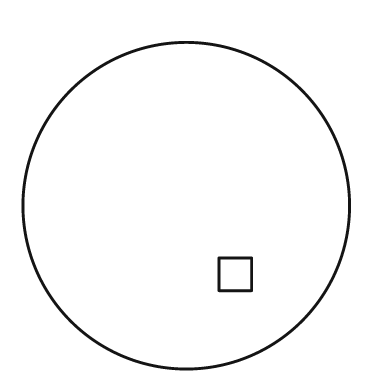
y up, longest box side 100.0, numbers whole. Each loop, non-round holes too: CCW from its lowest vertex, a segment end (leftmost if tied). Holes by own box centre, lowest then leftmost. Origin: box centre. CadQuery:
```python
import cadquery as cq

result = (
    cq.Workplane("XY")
    .moveTo(0.0, 0.0)
    .circle(50.0)
    .moveTo(10.0, -26.0)
    .lineTo(20.0, -26.0)
    .lineTo(20.0, -16.0)
    .lineTo(10.0, -16.0)
    .close()
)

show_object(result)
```